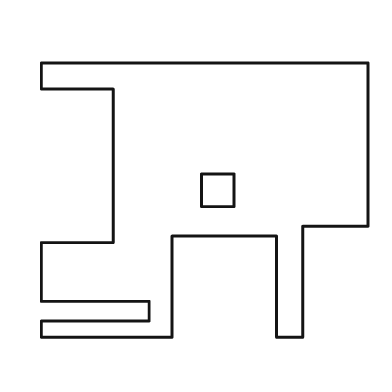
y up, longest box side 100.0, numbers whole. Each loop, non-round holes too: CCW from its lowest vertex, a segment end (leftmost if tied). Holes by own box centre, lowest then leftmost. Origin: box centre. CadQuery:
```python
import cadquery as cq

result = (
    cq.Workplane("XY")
    .moveTo(-50.0, -42.0)
    .lineTo(-10.0, -42.0)
    .lineTo(-10.0, -11.0)
    .lineTo(22.0, -11.0)
    .lineTo(22.0, -42.0)
    .lineTo(30.0, -42.0)
    .lineTo(30.0, -8.0)
    .lineTo(50.0, -8.0)
    .lineTo(50.0, 42.0)
    .lineTo(-50.0, 42.0)
    .lineTo(-50.0, 34.0)
    .lineTo(-28.0, 34.0)
    .lineTo(-28.0, -13.0)
    .lineTo(-50.0, -13.0)
    .lineTo(-50.0, -31.0)
    .lineTo(-17.0, -31.0)
    .lineTo(-17.0, -37.0)
    .lineTo(-50.0, -37.0)
    .close()
    .moveTo(-1.0, -2.0)
    .lineTo(9.0, -2.0)
    .lineTo(9.0, 8.0)
    .lineTo(-1.0, 8.0)
    .close()
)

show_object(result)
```